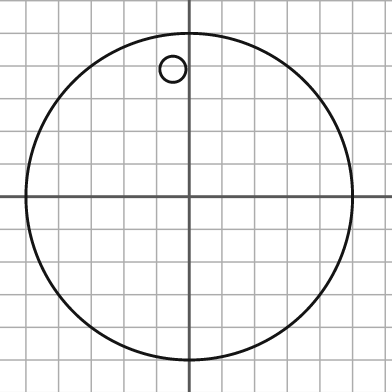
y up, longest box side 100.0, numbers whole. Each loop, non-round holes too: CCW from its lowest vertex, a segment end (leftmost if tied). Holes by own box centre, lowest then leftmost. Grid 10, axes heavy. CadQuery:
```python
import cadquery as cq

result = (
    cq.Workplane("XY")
    .moveTo(0.0, 0.0)
    .circle(50.0)
    .moveTo(-5.0, 39.0)
    .circle(4.0)
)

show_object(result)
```